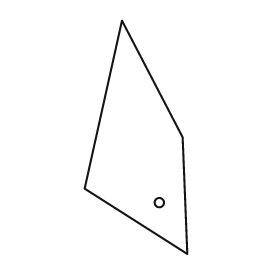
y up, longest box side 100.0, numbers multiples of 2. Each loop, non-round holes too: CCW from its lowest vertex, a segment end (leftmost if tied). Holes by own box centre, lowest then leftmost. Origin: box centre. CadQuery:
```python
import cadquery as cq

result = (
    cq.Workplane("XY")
    .moveTo(22.0, -50.0)
    .lineTo(20.0, 0.0)
    .lineTo(-6.0, 50.0)
    .lineTo(-22.0, -22.0)
    .close()
    .moveTo(10.0, -28.0)
    .circle(2.0)
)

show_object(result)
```